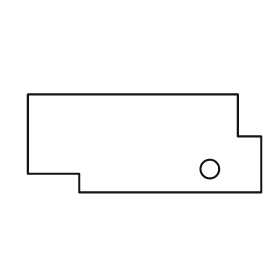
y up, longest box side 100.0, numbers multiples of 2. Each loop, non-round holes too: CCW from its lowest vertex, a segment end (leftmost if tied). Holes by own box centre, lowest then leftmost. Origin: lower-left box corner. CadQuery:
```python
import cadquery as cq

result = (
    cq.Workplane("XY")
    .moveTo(22.0, 0.0)
    .lineTo(100.0, 0.0)
    .lineTo(100.0, 24.0)
    .lineTo(90.0, 24.0)
    .lineTo(90.0, 42.0)
    .lineTo(0.0, 42.0)
    .lineTo(0.0, 8.0)
    .lineTo(22.0, 8.0)
    .close()
    .moveTo(78.0, 10.0)
    .circle(4.0)
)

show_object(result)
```